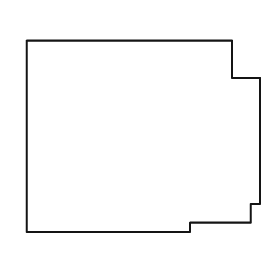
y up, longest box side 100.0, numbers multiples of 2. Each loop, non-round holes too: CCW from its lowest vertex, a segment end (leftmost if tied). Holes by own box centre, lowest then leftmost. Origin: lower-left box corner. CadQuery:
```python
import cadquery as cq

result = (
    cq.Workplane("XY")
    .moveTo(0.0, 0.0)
    .lineTo(70.0, 0.0)
    .lineTo(70.0, 4.0)
    .lineTo(96.0, 4.0)
    .lineTo(96.0, 12.0)
    .lineTo(100.0, 12.0)
    .lineTo(100.0, 66.0)
    .lineTo(88.0, 66.0)
    .lineTo(88.0, 82.0)
    .lineTo(0.0, 82.0)
    .close()
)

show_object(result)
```